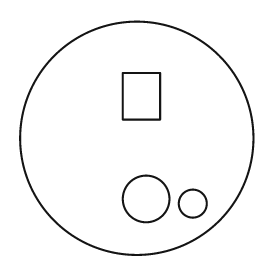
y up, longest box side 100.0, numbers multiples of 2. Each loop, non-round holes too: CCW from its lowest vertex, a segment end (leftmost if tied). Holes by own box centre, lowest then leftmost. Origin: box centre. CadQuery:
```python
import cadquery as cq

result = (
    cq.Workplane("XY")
    .moveTo(0.0, 0.0)
    .circle(50.0)
    .moveTo(24.0, -28.0)
    .circle(6.0)
    .moveTo(4.0, -26.0)
    .circle(10.0)
    .moveTo(-6.0, 8.0)
    .lineTo(10.0, 8.0)
    .lineTo(10.0, 28.0)
    .lineTo(-6.0, 28.0)
    .close()
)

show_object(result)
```